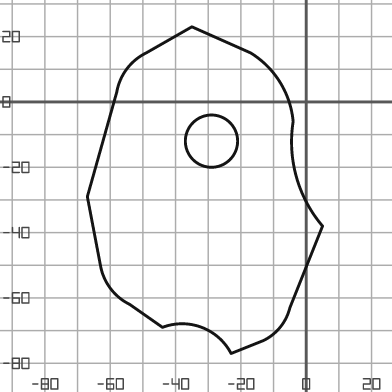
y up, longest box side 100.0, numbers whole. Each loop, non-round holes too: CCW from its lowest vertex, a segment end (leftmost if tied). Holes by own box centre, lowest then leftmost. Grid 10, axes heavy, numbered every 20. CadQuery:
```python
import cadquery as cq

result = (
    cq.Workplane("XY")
    .moveTo(-23.0, -77.0)
    .lineTo(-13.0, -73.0)
    .threePointArc((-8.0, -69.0), (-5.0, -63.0))
    .lineTo(5.0, -38.0)
    .threePointArc((-3.0, -23.0), (-4.0, -6.0))
    .threePointArc((-8.0, 6.0), (-17.0, 15.0))
    .lineTo(-35.0, 23.0)
    .lineTo(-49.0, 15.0)
    .threePointArc((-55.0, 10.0), (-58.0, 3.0))
    .lineTo(-67.0, -29.0)
    .lineTo(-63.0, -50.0)
    .threePointArc((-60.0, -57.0), (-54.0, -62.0))
    .lineTo(-44.0, -69.0)
    .threePointArc((-32.0, -69.0), (-23.0, -77.0))
    .close()
    .moveTo(-29.0, -12.0)
    .circle(8.0)
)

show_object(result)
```